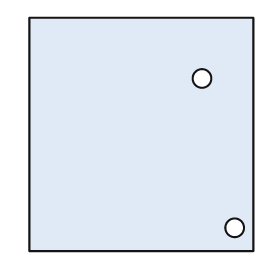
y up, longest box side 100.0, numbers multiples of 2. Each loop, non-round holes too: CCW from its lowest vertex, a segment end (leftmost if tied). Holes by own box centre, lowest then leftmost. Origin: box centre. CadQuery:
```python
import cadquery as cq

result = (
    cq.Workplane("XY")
    .moveTo(-48.0, -50.0)
    .lineTo(48.0, -50.0)
    .lineTo(48.0, 50.0)
    .lineTo(-48.0, 50.0)
    .close()
    .moveTo(40.0, -40.0)
    .circle(4.0)
    .moveTo(26.0, 24.0)
    .circle(4.0)
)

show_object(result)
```